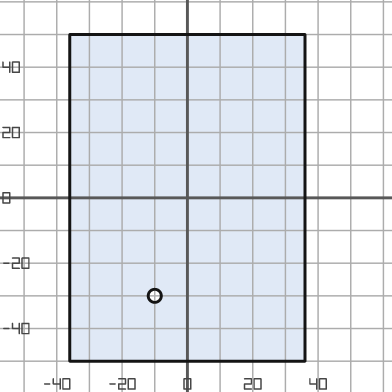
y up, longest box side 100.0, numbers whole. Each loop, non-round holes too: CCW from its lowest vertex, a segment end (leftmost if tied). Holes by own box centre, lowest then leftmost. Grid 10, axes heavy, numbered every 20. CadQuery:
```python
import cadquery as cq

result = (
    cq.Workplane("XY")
    .moveTo(-36.0, -50.0)
    .lineTo(36.0, -50.0)
    .lineTo(36.0, 50.0)
    .lineTo(-36.0, 50.0)
    .close()
    .moveTo(-10.0, -30.0)
    .circle(2.0)
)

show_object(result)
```